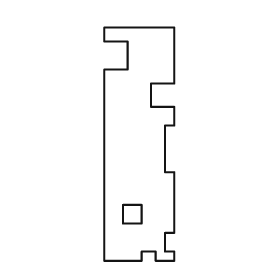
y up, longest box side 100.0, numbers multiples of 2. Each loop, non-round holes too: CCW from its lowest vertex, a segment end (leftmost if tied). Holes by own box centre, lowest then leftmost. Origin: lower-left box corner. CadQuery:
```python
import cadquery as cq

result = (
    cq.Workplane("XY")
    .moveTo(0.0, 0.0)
    .lineTo(16.0, 0.0)
    .lineTo(16.0, 4.0)
    .lineTo(22.0, 4.0)
    .lineTo(22.0, 0.0)
    .lineTo(30.0, 0.0)
    .lineTo(30.0, 4.0)
    .lineTo(26.0, 4.0)
    .lineTo(26.0, 12.0)
    .lineTo(30.0, 12.0)
    .lineTo(30.0, 38.0)
    .lineTo(26.0, 38.0)
    .lineTo(26.0, 58.0)
    .lineTo(30.0, 58.0)
    .lineTo(30.0, 66.0)
    .lineTo(20.0, 66.0)
    .lineTo(20.0, 76.0)
    .lineTo(30.0, 76.0)
    .lineTo(30.0, 100.0)
    .lineTo(0.0, 100.0)
    .lineTo(0.0, 94.0)
    .lineTo(10.0, 94.0)
    .lineTo(10.0, 82.0)
    .lineTo(0.0, 82.0)
    .close()
    .moveTo(8.0, 16.0)
    .lineTo(16.0, 16.0)
    .lineTo(16.0, 24.0)
    .lineTo(8.0, 24.0)
    .close()
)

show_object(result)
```